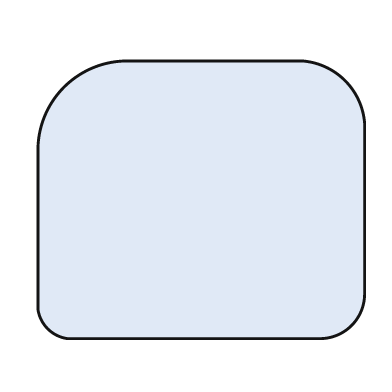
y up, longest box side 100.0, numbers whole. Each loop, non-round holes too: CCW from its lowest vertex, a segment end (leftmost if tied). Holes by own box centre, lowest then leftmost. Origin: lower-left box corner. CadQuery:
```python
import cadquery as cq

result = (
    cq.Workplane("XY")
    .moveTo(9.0, 0.0)
    .lineTo(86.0, 0.0)
    .threePointArc((96.0, 4.0), (100.0, 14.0))
    .lineTo(100.0, 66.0)
    .threePointArc((94.0, 79.0), (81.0, 85.0))
    .lineTo(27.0, 85.0)
    .threePointArc((8.0, 77.0), (0.0, 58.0))
    .lineTo(0.0, 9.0)
    .threePointArc((3.0, 3.0), (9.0, 0.0))
    .close()
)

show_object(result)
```